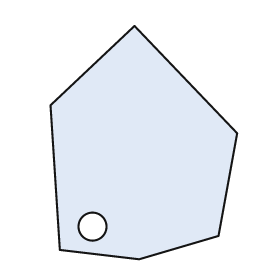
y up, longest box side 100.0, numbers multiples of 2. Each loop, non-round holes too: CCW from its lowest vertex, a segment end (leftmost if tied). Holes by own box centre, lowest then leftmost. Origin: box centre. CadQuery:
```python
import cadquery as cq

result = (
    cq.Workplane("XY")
    .moveTo(-2.0, -50.0)
    .lineTo(32.0, -40.0)
    .lineTo(40.0, 4.0)
    .lineTo(-4.0, 50.0)
    .lineTo(-40.0, 16.0)
    .lineTo(-36.0, -46.0)
    .close()
    .moveTo(-22.0, -36.0)
    .circle(6.0)
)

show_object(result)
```